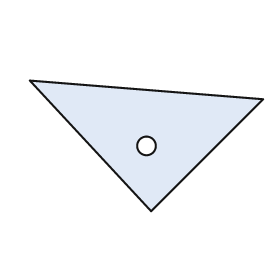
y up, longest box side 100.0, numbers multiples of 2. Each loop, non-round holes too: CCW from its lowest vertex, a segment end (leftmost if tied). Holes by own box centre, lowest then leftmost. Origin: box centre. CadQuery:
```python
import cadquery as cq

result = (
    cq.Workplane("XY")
    .moveTo(2.0, -28.0)
    .lineTo(50.0, 20.0)
    .lineTo(-50.0, 28.0)
    .close()
    .moveTo(0.0, 0.0)
    .circle(4.0)
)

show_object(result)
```